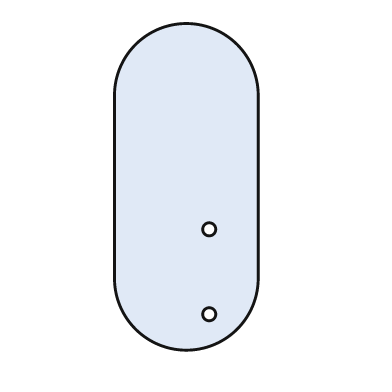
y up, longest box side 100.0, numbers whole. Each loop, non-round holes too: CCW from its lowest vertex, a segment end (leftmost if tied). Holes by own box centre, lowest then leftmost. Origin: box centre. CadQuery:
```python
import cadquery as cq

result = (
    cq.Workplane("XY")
    .moveTo(-22.0, -28.0)
    .threePointArc((0.0, -50.0), (22.0, -28.0))
    .lineTo(22.0, 28.0)
    .threePointArc((0.0, 50.0), (-22.0, 28.0))
    .close()
    .moveTo(7.0, -39.0)
    .circle(2.0)
    .moveTo(7.0, -13.0)
    .circle(2.0)
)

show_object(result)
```